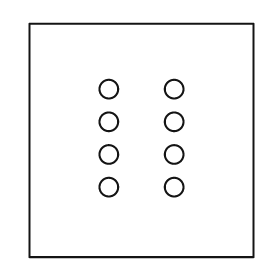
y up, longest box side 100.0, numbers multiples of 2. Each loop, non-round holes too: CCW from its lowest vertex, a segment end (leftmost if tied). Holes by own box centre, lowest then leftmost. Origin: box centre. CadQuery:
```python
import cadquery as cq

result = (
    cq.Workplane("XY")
    .moveTo(-48.0, -50.0)
    .lineTo(48.0, -50.0)
    .lineTo(48.0, 50.0)
    .lineTo(-48.0, 50.0)
    .close()
    .moveTo(-14.0, -20.0)
    .circle(4.0)
    .moveTo(14.0, -20.0)
    .circle(4.0)
    .moveTo(-14.0, -6.0)
    .circle(4.0)
    .moveTo(14.0, -6.0)
    .circle(4.0)
    .moveTo(-14.0, 8.0)
    .circle(4.0)
    .moveTo(14.0, 8.0)
    .circle(4.0)
    .moveTo(-14.0, 22.0)
    .circle(4.0)
    .moveTo(14.0, 22.0)
    .circle(4.0)
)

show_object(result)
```